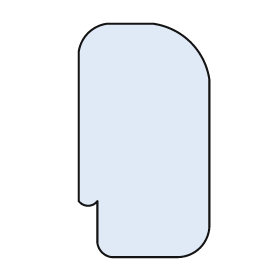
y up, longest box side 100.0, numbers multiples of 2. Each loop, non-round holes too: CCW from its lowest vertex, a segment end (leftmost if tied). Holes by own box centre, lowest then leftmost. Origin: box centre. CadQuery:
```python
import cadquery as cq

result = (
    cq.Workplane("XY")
    .moveTo(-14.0, -50.0)
    .lineTo(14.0, -50.0)
    .threePointArc((24.0, -46.0), (28.0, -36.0))
    .lineTo(28.0, 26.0)
    .threePointArc((20.0, 42.0), (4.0, 50.0))
    .lineTo(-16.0, 50.0)
    .threePointArc((-24.0, 46.0), (-28.0, 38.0))
    .lineTo(-28.0, -26.0)
    .threePointArc((-24.0, -28.0), (-20.0, -26.0))
    .lineTo(-20.0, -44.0)
    .threePointArc((-18.0, -48.0), (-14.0, -50.0))
    .close()
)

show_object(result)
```